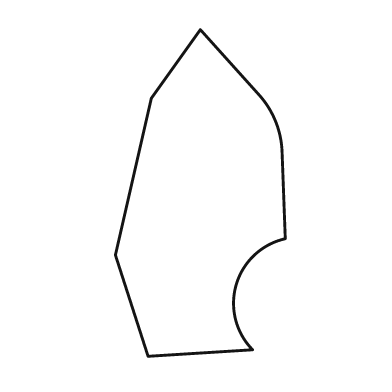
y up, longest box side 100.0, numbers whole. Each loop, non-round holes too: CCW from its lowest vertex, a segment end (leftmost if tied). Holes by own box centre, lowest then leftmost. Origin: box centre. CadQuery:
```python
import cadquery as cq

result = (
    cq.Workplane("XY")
    .moveTo(-16.0, -50.0)
    .lineTo(16.0, -48.0)
    .threePointArc((11.0, -28.0), (26.0, -14.0))
    .lineTo(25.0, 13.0)
    .threePointArc((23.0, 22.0), (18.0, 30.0))
    .lineTo(0.0, 50.0)
    .lineTo(-15.0, 29.0)
    .lineTo(-26.0, -19.0)
    .close()
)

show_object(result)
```